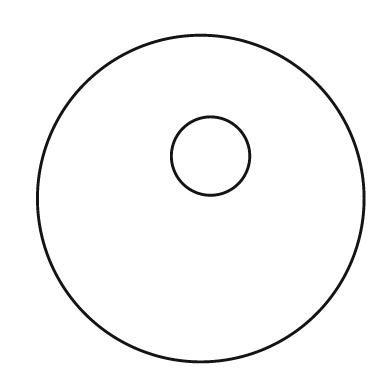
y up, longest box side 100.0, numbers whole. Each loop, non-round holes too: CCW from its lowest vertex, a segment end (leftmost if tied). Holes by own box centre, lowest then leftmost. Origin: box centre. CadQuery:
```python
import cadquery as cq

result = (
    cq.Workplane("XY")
    .moveTo(0.0, 0.0)
    .circle(50.0)
    .moveTo(3.0, 13.0)
    .circle(12.0)
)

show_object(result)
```